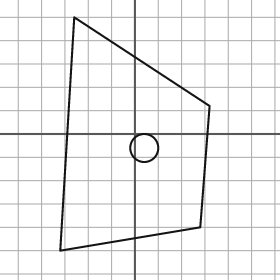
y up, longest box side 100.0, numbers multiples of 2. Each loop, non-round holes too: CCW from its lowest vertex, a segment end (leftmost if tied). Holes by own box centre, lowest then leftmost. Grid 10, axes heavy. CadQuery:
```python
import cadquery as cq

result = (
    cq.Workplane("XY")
    .moveTo(-32.0, -50.0)
    .lineTo(28.0, -40.0)
    .lineTo(32.0, 12.0)
    .lineTo(-26.0, 50.0)
    .close()
    .moveTo(4.0, -6.0)
    .circle(6.0)
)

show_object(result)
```